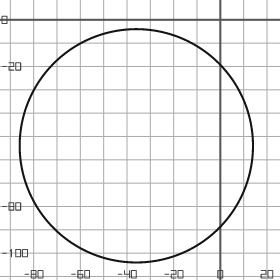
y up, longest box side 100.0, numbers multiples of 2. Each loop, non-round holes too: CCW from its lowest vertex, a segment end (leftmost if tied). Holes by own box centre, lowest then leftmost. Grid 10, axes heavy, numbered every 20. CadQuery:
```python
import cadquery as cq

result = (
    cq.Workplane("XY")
    .moveTo(-36.0, -54.0)
    .circle(50.0)
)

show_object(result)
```